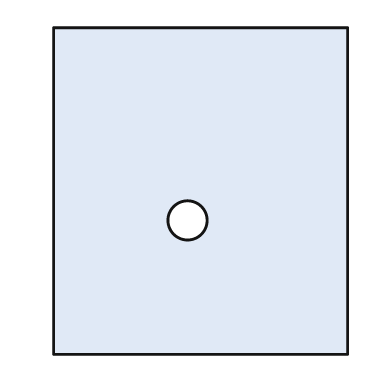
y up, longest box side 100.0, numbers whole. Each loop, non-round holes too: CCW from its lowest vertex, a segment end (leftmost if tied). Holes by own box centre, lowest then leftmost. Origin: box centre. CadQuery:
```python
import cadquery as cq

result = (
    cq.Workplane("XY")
    .moveTo(-45.0, -50.0)
    .lineTo(45.0, -50.0)
    .lineTo(45.0, 50.0)
    .lineTo(-45.0, 50.0)
    .close()
    .moveTo(-4.0, -9.0)
    .circle(6.0)
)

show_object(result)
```